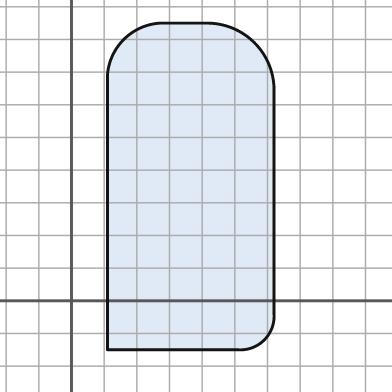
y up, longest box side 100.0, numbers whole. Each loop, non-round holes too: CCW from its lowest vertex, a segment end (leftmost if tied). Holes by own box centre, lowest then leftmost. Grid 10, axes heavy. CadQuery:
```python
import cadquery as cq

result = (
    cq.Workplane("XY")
    .moveTo(11.0, -15.0)
    .lineTo(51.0, -15.0)
    .threePointArc((59.0, -12.0), (62.0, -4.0))
    .lineTo(62.0, 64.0)
    .threePointArc((56.0, 79.0), (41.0, 85.0))
    .lineTo(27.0, 85.0)
    .threePointArc((16.0, 80.0), (11.0, 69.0))
    .close()
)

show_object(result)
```